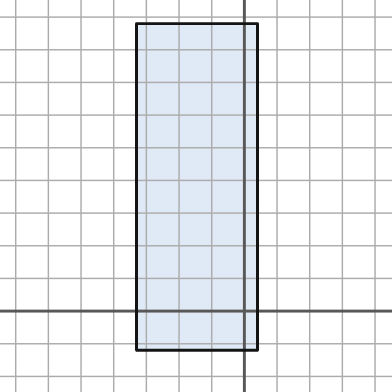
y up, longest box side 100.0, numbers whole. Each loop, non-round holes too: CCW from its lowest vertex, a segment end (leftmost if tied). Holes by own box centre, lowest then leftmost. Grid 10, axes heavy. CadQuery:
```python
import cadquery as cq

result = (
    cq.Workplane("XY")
    .moveTo(-33.0, -12.0)
    .lineTo(4.0, -12.0)
    .lineTo(4.0, 88.0)
    .lineTo(-33.0, 88.0)
    .close()
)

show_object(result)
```